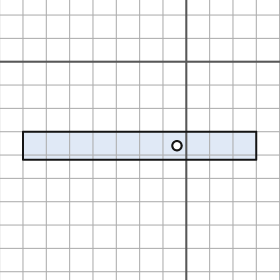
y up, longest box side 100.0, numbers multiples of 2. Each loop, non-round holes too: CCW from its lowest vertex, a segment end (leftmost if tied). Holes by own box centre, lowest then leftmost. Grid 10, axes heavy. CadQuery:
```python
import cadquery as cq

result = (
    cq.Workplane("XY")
    .moveTo(-70.0, -42.0)
    .lineTo(30.0, -42.0)
    .lineTo(30.0, -30.0)
    .lineTo(-70.0, -30.0)
    .close()
    .moveTo(-4.0, -36.0)
    .circle(2.0)
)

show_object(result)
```